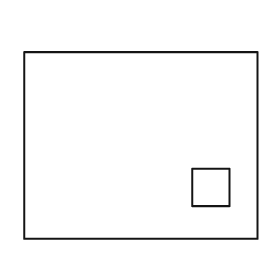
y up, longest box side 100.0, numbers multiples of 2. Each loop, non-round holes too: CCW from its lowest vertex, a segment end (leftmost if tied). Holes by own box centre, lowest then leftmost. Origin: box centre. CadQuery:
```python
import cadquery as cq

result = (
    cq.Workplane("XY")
    .moveTo(-50.0, -40.0)
    .lineTo(50.0, -40.0)
    .lineTo(50.0, 40.0)
    .lineTo(-50.0, 40.0)
    .close()
    .moveTo(22.0, -26.0)
    .lineTo(38.0, -26.0)
    .lineTo(38.0, -10.0)
    .lineTo(22.0, -10.0)
    .close()
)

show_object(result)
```